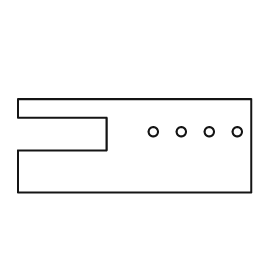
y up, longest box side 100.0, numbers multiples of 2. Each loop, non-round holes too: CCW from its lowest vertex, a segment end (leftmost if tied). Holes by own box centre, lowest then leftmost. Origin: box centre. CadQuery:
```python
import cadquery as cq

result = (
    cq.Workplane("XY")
    .moveTo(-50.0, -20.0)
    .lineTo(50.0, -20.0)
    .lineTo(50.0, 20.0)
    .lineTo(-50.0, 20.0)
    .lineTo(-50.0, 12.0)
    .lineTo(-12.0, 12.0)
    .lineTo(-12.0, -2.0)
    .lineTo(-50.0, -2.0)
    .close()
    .moveTo(8.0, 6.0)
    .circle(2.0)
    .moveTo(20.0, 6.0)
    .circle(2.0)
    .moveTo(32.0, 6.0)
    .circle(2.0)
    .moveTo(44.0, 6.0)
    .circle(2.0)
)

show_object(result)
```